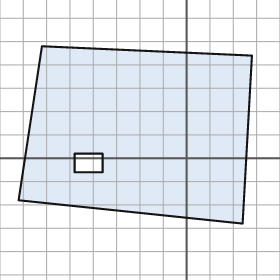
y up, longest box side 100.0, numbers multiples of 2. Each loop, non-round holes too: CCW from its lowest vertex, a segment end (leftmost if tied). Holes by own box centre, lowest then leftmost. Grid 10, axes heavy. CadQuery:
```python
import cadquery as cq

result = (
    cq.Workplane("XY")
    .moveTo(24.0, -28.0)
    .lineTo(28.0, 44.0)
    .lineTo(-62.0, 48.0)
    .lineTo(-72.0, -18.0)
    .close()
    .moveTo(-48.0, -6.0)
    .lineTo(-36.0, -6.0)
    .lineTo(-36.0, 2.0)
    .lineTo(-48.0, 2.0)
    .close()
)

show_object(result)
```